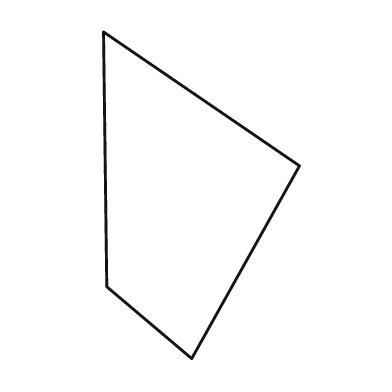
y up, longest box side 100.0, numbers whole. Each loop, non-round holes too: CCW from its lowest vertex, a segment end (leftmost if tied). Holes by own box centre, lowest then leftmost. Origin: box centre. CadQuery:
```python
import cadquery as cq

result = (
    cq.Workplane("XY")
    .moveTo(-3.0, -50.0)
    .lineTo(30.0, 9.0)
    .lineTo(-30.0, 50.0)
    .lineTo(-29.0, -28.0)
    .close()
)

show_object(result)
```